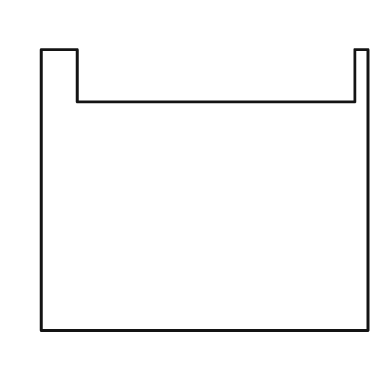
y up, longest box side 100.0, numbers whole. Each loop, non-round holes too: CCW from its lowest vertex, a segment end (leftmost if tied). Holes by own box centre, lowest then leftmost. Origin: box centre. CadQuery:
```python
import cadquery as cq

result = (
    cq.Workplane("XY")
    .moveTo(-50.0, -43.0)
    .lineTo(50.0, -43.0)
    .lineTo(50.0, 43.0)
    .lineTo(46.0, 43.0)
    .lineTo(46.0, 27.0)
    .lineTo(-39.0, 27.0)
    .lineTo(-39.0, 43.0)
    .lineTo(-50.0, 43.0)
    .close()
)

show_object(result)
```